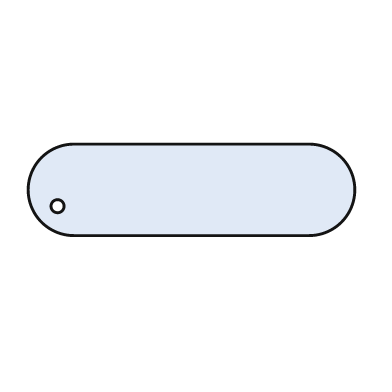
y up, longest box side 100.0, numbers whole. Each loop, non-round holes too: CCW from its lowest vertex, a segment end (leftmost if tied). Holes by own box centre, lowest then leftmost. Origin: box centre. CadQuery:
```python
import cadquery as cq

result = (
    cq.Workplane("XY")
    .moveTo(-36.0, -14.0)
    .lineTo(36.0, -14.0)
    .threePointArc((50.0, 0.0), (36.0, 14.0))
    .lineTo(-36.0, 14.0)
    .threePointArc((-50.0, 0.0), (-36.0, -14.0))
    .close()
    .moveTo(-41.0, -5.0)
    .circle(2.0)
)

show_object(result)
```